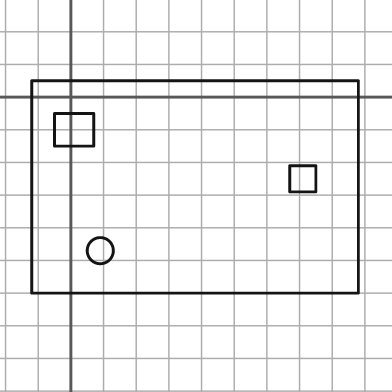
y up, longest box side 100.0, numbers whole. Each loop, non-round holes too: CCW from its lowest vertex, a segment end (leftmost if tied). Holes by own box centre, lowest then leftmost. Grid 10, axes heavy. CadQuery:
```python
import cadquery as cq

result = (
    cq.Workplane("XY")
    .moveTo(-12.0, -60.0)
    .lineTo(88.0, -60.0)
    .lineTo(88.0, 5.0)
    .lineTo(-12.0, 5.0)
    .close()
    .moveTo(9.0, -47.0)
    .circle(4.0)
    .moveTo(67.0, -29.0)
    .lineTo(75.0, -29.0)
    .lineTo(75.0, -21.0)
    .lineTo(67.0, -21.0)
    .close()
    .moveTo(-5.0, -15.0)
    .lineTo(7.0, -15.0)
    .lineTo(7.0, -5.0)
    .lineTo(-5.0, -5.0)
    .close()
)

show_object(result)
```